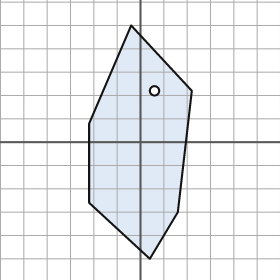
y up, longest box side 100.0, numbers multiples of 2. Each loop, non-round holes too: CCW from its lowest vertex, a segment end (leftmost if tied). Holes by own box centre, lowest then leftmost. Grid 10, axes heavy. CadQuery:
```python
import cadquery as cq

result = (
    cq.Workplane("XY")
    .moveTo(4.0, -50.0)
    .lineTo(16.0, -30.0)
    .lineTo(22.0, 22.0)
    .lineTo(-4.0, 50.0)
    .lineTo(-22.0, 8.0)
    .lineTo(-22.0, -26.0)
    .close()
    .moveTo(6.0, 22.0)
    .circle(2.0)
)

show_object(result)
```